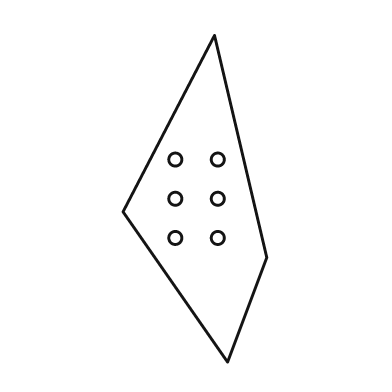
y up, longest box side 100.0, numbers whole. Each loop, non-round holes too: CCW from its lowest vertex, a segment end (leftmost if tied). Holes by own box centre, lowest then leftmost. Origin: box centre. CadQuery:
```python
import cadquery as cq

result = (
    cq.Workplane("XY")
    .moveTo(10.0, -50.0)
    .lineTo(22.0, -18.0)
    .lineTo(6.0, 50.0)
    .lineTo(-22.0, -4.0)
    .close()
    .moveTo(-6.0, -12.0)
    .circle(2.0)
    .moveTo(7.0, -12.0)
    .circle(2.0)
    .moveTo(-6.0, 0.0)
    .circle(2.0)
    .moveTo(7.0, 0.0)
    .circle(2.0)
    .moveTo(-6.0, 12.0)
    .circle(2.0)
    .moveTo(7.0, 12.0)
    .circle(2.0)
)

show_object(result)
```